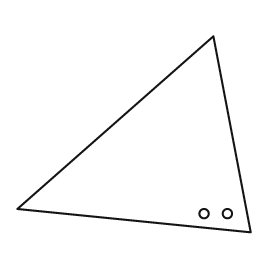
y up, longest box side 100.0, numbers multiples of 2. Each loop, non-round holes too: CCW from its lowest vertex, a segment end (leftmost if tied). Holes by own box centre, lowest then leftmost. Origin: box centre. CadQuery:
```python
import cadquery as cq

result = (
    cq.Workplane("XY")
    .moveTo(50.0, -42.0)
    .lineTo(34.0, 42.0)
    .lineTo(-50.0, -32.0)
    .close()
    .moveTo(30.0, -34.0)
    .circle(2.0)
    .moveTo(40.0, -34.0)
    .circle(2.0)
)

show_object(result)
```